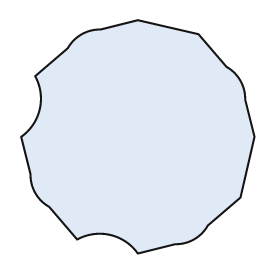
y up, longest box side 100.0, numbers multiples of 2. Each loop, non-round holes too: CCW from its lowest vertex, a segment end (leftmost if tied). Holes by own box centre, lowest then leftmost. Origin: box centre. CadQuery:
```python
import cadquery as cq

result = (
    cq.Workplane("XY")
    .moveTo(0.0, -50.0)
    .lineTo(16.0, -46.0)
    .threePointArc((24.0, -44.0), (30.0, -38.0))
    .lineTo(44.0, -26.0)
    .lineTo(50.0, 0.0)
    .lineTo(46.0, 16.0)
    .threePointArc((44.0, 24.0), (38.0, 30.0))
    .lineTo(26.0, 44.0)
    .lineTo(0.0, 50.0)
    .lineTo(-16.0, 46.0)
    .threePointArc((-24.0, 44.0), (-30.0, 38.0))
    .lineTo(-44.0, 26.0)
    .threePointArc((-42.0, 12.0), (-50.0, 0.0))
    .lineTo(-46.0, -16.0)
    .threePointArc((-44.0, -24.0), (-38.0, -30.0))
    .lineTo(-26.0, -44.0)
    .threePointArc((-12.0, -42.0), (0.0, -50.0))
    .close()
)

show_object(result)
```